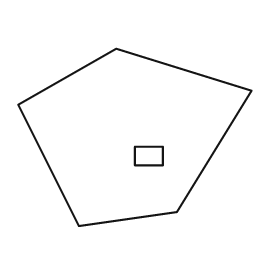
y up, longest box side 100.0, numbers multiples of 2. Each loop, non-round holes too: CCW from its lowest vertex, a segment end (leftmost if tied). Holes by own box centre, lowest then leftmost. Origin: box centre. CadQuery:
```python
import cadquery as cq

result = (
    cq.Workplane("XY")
    .moveTo(-24.0, -38.0)
    .lineTo(18.0, -32.0)
    .lineTo(50.0, 20.0)
    .lineTo(-8.0, 38.0)
    .lineTo(-50.0, 14.0)
    .close()
    .moveTo(0.0, -12.0)
    .lineTo(12.0, -12.0)
    .lineTo(12.0, -4.0)
    .lineTo(0.0, -4.0)
    .close()
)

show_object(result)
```